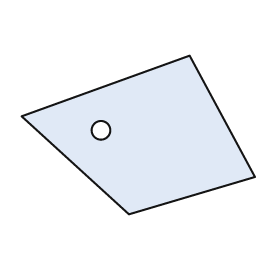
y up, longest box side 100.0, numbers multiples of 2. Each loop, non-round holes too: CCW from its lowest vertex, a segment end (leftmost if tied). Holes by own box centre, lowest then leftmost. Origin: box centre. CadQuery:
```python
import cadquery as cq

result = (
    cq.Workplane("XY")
    .moveTo(-4.0, -34.0)
    .lineTo(50.0, -18.0)
    .lineTo(22.0, 34.0)
    .lineTo(-50.0, 8.0)
    .close()
    .moveTo(-16.0, 2.0)
    .circle(4.0)
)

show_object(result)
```